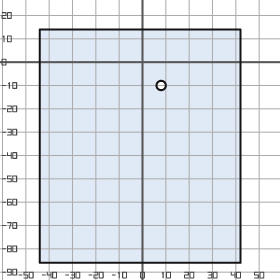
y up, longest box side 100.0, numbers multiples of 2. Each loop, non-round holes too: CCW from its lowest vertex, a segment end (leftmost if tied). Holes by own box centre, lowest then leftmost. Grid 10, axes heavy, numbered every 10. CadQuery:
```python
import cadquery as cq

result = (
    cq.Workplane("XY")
    .moveTo(-44.0, -86.0)
    .lineTo(42.0, -86.0)
    .lineTo(42.0, 14.0)
    .lineTo(-44.0, 14.0)
    .close()
    .moveTo(8.0, -10.0)
    .circle(2.0)
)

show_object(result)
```